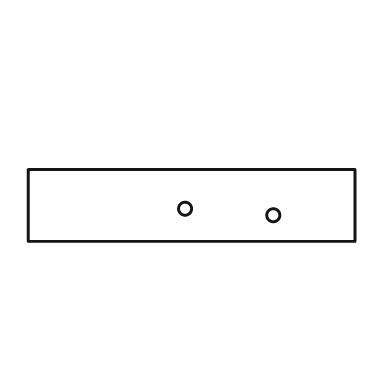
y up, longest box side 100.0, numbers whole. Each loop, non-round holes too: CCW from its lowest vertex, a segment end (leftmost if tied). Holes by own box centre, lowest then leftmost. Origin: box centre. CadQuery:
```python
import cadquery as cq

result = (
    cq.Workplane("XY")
    .moveTo(-50.0, -11.0)
    .lineTo(50.0, -11.0)
    .lineTo(50.0, 11.0)
    .lineTo(-50.0, 11.0)
    .close()
    .moveTo(25.0, -3.0)
    .circle(2.0)
    .moveTo(-2.0, -1.0)
    .circle(2.0)
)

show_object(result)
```